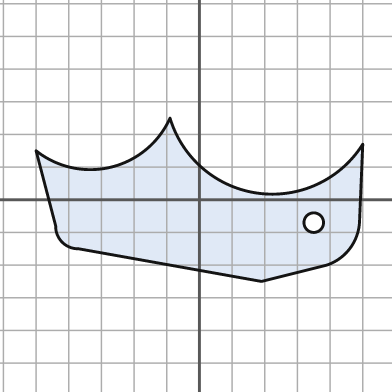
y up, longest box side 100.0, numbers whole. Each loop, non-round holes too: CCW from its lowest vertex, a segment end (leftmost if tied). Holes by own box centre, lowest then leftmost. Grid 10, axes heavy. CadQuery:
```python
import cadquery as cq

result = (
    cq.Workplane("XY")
    .moveTo(19.0, -25.0)
    .lineTo(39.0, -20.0)
    .threePointArc((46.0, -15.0), (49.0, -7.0))
    .lineTo(50.0, 17.0)
    .threePointArc((18.0, 2.0), (-9.0, 25.0))
    .threePointArc((-27.0, 10.0), (-50.0, 15.0))
    .lineTo(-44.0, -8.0)
    .threePointArc((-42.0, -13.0), (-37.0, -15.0))
    .close()
    .moveTo(35.0, -7.0)
    .circle(3.0)
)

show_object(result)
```